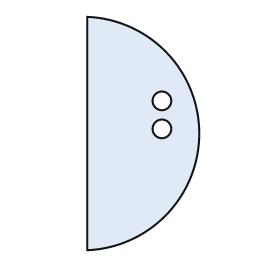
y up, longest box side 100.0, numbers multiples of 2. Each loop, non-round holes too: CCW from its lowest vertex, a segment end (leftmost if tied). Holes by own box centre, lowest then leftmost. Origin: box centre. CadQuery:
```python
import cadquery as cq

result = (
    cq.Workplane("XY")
    .moveTo(-24.0, -50.0)
    .threePointArc((24.0, 0.0), (-24.0, 50.0))
    .close()
    .moveTo(8.0, 2.0)
    .circle(4.0)
    .moveTo(8.0, 14.0)
    .circle(4.0)
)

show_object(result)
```